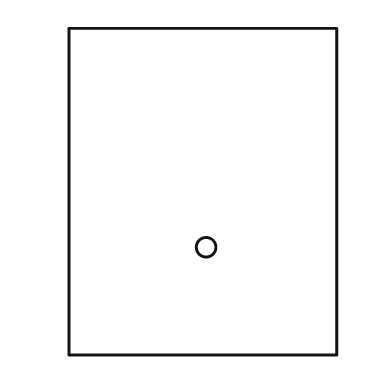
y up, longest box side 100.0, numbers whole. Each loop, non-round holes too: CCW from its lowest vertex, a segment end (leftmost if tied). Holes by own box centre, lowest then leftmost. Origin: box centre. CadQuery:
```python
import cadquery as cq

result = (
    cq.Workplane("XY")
    .moveTo(-41.0, -50.0)
    .lineTo(41.0, -50.0)
    .lineTo(41.0, 50.0)
    .lineTo(-41.0, 50.0)
    .close()
    .moveTo(1.0, -17.0)
    .circle(3.0)
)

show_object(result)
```